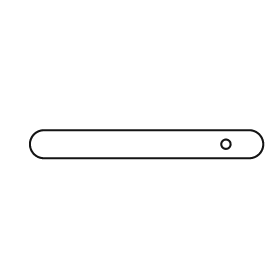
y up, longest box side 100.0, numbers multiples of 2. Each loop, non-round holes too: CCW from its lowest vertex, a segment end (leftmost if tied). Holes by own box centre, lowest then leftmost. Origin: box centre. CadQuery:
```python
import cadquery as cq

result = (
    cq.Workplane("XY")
    .moveTo(-44.0, -6.0)
    .lineTo(44.0, -6.0)
    .threePointArc((50.0, 0.0), (44.0, 6.0))
    .lineTo(-44.0, 6.0)
    .threePointArc((-50.0, 0.0), (-44.0, -6.0))
    .close()
    .moveTo(34.0, 0.0)
    .circle(2.0)
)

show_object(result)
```